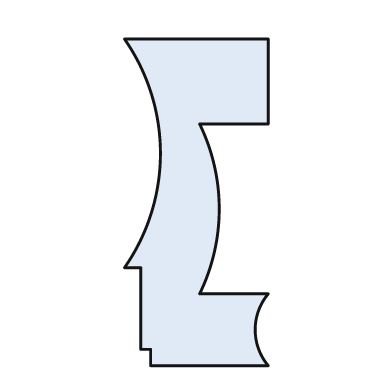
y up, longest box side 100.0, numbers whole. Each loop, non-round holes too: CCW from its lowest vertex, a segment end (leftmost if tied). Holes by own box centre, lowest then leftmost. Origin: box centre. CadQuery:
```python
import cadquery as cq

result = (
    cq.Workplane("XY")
    .moveTo(-14.0, -50.0)
    .lineTo(22.0, -50.0)
    .threePointArc((18.0, -39.0), (22.0, -28.0))
    .lineTo(1.0, -28.0)
    .threePointArc((7.0, -2.0), (1.0, 24.0))
    .lineTo(22.0, 24.0)
    .lineTo(22.0, 50.0)
    .lineTo(-22.0, 50.0)
    .threePointArc((-11.0, 15.0), (-22.0, -20.0))
    .lineTo(-17.0, -20.0)
    .lineTo(-17.0, -45.0)
    .lineTo(-14.0, -45.0)
    .close()
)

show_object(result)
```